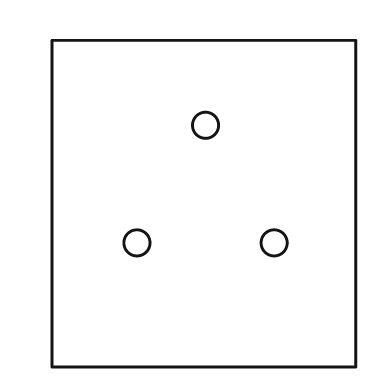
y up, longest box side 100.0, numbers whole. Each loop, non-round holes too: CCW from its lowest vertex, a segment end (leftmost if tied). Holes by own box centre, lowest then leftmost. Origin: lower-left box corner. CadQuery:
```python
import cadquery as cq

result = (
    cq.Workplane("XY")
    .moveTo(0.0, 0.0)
    .lineTo(93.0, 0.0)
    .lineTo(93.0, 100.0)
    .lineTo(0.0, 100.0)
    .close()
    .moveTo(26.0, 38.0)
    .circle(4.0)
    .moveTo(68.0, 38.0)
    .circle(4.0)
    .moveTo(47.0, 74.0)
    .circle(4.0)
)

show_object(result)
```